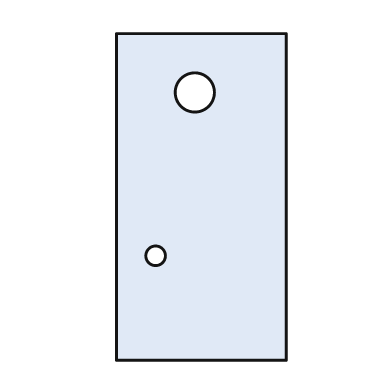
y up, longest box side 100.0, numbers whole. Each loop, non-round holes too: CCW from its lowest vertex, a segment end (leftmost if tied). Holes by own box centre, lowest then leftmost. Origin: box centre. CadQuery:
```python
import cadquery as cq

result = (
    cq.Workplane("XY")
    .moveTo(-26.0, -50.0)
    .lineTo(26.0, -50.0)
    .lineTo(26.0, 50.0)
    .lineTo(-26.0, 50.0)
    .close()
    .moveTo(-14.0, -18.0)
    .circle(3.0)
    .moveTo(-2.0, 32.0)
    .circle(6.0)
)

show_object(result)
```